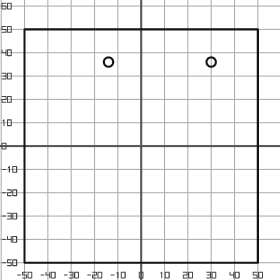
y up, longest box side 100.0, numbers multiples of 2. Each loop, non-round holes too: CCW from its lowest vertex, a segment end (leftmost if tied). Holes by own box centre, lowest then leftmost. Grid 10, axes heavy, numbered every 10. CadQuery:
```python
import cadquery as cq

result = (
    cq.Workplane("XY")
    .moveTo(-50.0, -50.0)
    .lineTo(50.0, -50.0)
    .lineTo(50.0, 50.0)
    .lineTo(-50.0, 50.0)
    .close()
    .moveTo(-14.0, 36.0)
    .circle(2.0)
    .moveTo(30.0, 36.0)
    .circle(2.0)
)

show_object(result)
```